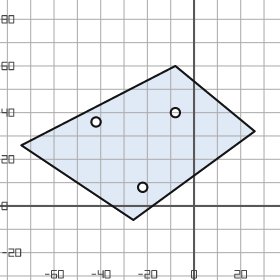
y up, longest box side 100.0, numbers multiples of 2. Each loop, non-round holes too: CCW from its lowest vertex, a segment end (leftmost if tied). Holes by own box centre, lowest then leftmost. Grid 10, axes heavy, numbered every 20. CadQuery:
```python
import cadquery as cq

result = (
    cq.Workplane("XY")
    .moveTo(-26.0, -6.0)
    .lineTo(26.0, 32.0)
    .lineTo(-8.0, 60.0)
    .lineTo(-74.0, 26.0)
    .close()
    .moveTo(-22.0, 8.0)
    .circle(2.0)
    .moveTo(-42.0, 36.0)
    .circle(2.0)
    .moveTo(-8.0, 40.0)
    .circle(2.0)
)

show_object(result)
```